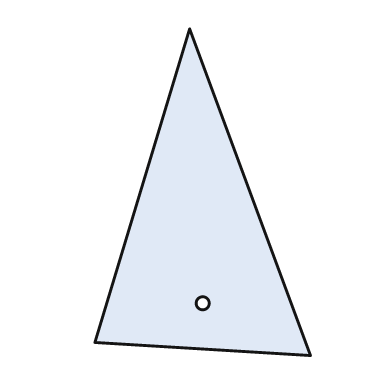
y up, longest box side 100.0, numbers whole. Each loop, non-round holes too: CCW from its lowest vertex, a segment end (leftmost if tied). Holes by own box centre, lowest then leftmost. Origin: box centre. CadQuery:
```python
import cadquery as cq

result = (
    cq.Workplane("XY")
    .moveTo(33.0, -50.0)
    .lineTo(-4.0, 50.0)
    .lineTo(-33.0, -46.0)
    .close()
    .moveTo(0.0, -34.0)
    .circle(2.0)
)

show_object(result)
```